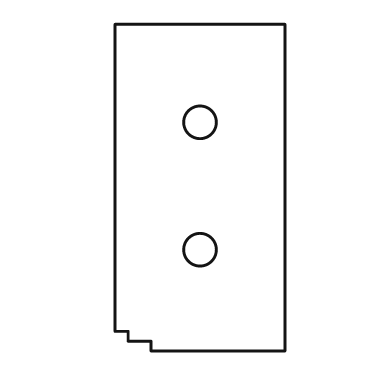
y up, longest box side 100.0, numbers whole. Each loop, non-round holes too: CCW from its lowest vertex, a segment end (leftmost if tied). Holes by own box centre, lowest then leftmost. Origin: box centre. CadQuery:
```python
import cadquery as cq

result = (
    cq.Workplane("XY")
    .moveTo(-15.0, -50.0)
    .lineTo(26.0, -50.0)
    .lineTo(26.0, 50.0)
    .lineTo(-26.0, 50.0)
    .lineTo(-26.0, -44.0)
    .lineTo(-22.0, -44.0)
    .lineTo(-22.0, -47.0)
    .lineTo(-15.0, -47.0)
    .close()
    .moveTo(0.0, -19.0)
    .circle(5.0)
    .moveTo(0.0, 20.0)
    .circle(5.0)
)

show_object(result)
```